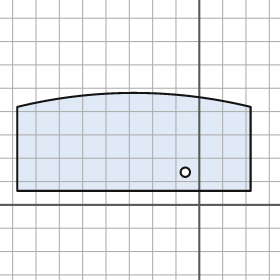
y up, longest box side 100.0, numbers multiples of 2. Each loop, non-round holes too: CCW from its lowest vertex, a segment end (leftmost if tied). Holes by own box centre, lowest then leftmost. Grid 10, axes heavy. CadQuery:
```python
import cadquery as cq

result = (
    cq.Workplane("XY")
    .moveTo(-78.0, 6.0)
    .lineTo(22.0, 6.0)
    .lineTo(22.0, 42.0)
    .threePointArc((-28.0, 48.0), (-78.0, 42.0))
    .close()
    .moveTo(-6.0, 14.0)
    .circle(2.0)
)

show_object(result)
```